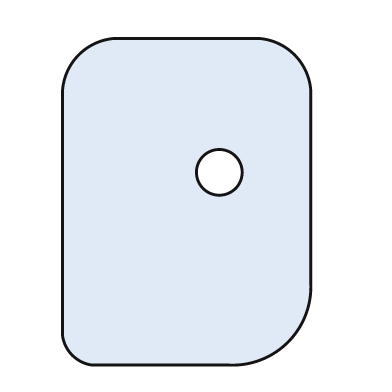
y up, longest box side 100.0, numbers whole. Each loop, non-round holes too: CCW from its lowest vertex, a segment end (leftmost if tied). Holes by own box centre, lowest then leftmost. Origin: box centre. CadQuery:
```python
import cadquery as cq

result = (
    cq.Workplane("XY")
    .moveTo(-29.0, -50.0)
    .lineTo(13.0, -50.0)
    .threePointArc((31.0, -43.0), (38.0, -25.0))
    .lineTo(38.0, 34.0)
    .threePointArc((33.0, 45.0), (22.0, 50.0))
    .lineTo(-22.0, 50.0)
    .threePointArc((-33.0, 45.0), (-38.0, 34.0))
    .lineTo(-38.0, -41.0)
    .threePointArc((-35.0, -47.0), (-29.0, -50.0))
    .close()
    .moveTo(10.0, 9.0)
    .circle(7.0)
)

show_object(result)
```